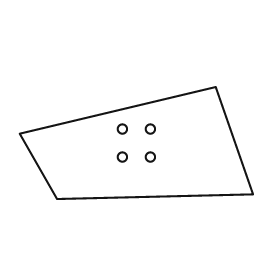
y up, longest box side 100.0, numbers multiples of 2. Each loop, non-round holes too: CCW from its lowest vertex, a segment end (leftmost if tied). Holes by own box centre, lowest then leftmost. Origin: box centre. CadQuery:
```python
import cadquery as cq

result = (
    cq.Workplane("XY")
    .moveTo(-34.0, -24.0)
    .lineTo(50.0, -22.0)
    .lineTo(34.0, 24.0)
    .lineTo(-50.0, 4.0)
    .close()
    .moveTo(-6.0, -6.0)
    .circle(2.0)
    .moveTo(6.0, -6.0)
    .circle(2.0)
    .moveTo(-6.0, 6.0)
    .circle(2.0)
    .moveTo(6.0, 6.0)
    .circle(2.0)
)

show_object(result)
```